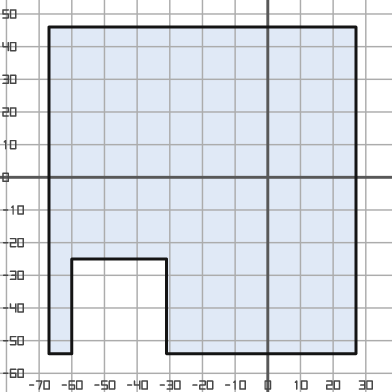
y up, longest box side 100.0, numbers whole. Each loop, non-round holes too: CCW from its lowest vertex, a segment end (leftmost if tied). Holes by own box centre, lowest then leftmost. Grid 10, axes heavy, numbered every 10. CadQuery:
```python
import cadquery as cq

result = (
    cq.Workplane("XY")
    .moveTo(-67.0, -54.0)
    .lineTo(-60.0, -54.0)
    .lineTo(-60.0, -25.0)
    .lineTo(-31.0, -25.0)
    .lineTo(-31.0, -54.0)
    .lineTo(27.0, -54.0)
    .lineTo(27.0, 46.0)
    .lineTo(-67.0, 46.0)
    .close()
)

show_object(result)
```